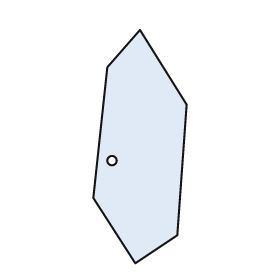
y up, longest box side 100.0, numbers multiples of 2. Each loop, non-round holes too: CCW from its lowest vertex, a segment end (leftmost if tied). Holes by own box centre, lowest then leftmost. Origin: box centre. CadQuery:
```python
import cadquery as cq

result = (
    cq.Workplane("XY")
    .moveTo(-2.0, -50.0)
    .lineTo(16.0, -38.0)
    .lineTo(20.0, 18.0)
    .lineTo(0.0, 50.0)
    .lineTo(-14.0, 34.0)
    .lineTo(-20.0, -22.0)
    .close()
    .moveTo(-12.0, -6.0)
    .circle(2.0)
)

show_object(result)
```